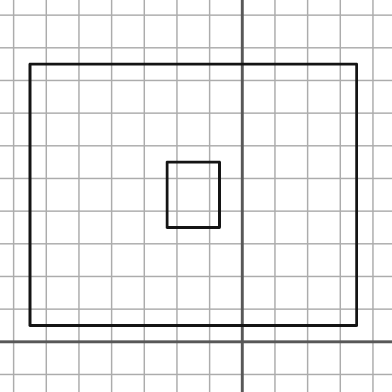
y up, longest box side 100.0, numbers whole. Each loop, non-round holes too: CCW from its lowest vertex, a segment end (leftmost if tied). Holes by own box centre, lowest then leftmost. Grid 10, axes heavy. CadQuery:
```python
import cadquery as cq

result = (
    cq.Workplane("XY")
    .moveTo(-65.0, 5.0)
    .lineTo(35.0, 5.0)
    .lineTo(35.0, 85.0)
    .lineTo(-65.0, 85.0)
    .close()
    .moveTo(-23.0, 35.0)
    .lineTo(-7.0, 35.0)
    .lineTo(-7.0, 55.0)
    .lineTo(-23.0, 55.0)
    .close()
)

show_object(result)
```